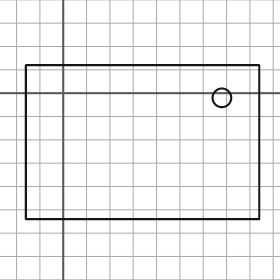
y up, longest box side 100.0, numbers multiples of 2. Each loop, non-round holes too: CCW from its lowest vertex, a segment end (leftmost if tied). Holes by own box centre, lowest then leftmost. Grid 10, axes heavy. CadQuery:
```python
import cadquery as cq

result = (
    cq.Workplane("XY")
    .moveTo(-16.0, -54.0)
    .lineTo(84.0, -54.0)
    .lineTo(84.0, 12.0)
    .lineTo(-16.0, 12.0)
    .close()
    .moveTo(68.0, -2.0)
    .circle(4.0)
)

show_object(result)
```